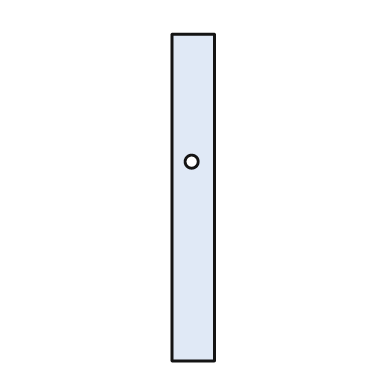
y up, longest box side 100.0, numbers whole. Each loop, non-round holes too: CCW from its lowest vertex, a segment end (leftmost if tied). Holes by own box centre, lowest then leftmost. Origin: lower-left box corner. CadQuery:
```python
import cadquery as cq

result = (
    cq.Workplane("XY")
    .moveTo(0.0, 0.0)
    .lineTo(13.0, 0.0)
    .lineTo(13.0, 100.0)
    .lineTo(0.0, 100.0)
    .close()
    .moveTo(6.0, 61.0)
    .circle(2.0)
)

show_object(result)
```